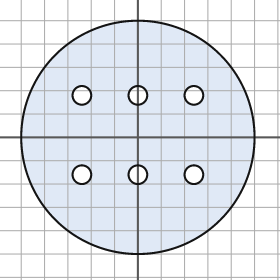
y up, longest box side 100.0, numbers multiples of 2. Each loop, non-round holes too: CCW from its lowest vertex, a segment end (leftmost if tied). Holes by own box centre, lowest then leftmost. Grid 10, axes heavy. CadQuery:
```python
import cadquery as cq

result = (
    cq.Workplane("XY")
    .moveTo(0.0, 0.0)
    .circle(50.0)
    .moveTo(-24.0, -16.0)
    .circle(4.0)
    .moveTo(0.0, -16.0)
    .circle(4.0)
    .moveTo(24.0, -16.0)
    .circle(4.0)
    .moveTo(-24.0, 18.0)
    .circle(4.0)
    .moveTo(0.0, 18.0)
    .circle(4.0)
    .moveTo(24.0, 18.0)
    .circle(4.0)
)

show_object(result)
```